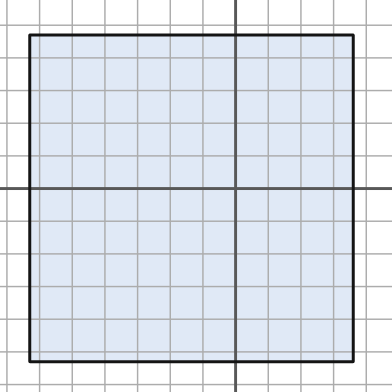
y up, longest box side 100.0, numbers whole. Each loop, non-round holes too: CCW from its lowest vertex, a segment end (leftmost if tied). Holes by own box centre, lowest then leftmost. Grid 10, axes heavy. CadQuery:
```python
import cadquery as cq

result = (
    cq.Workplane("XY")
    .moveTo(-63.0, -53.0)
    .lineTo(36.0, -53.0)
    .lineTo(36.0, 47.0)
    .lineTo(-63.0, 47.0)
    .close()
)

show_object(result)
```